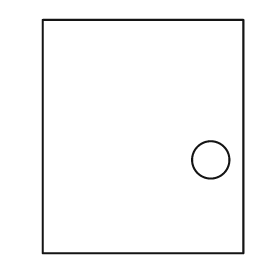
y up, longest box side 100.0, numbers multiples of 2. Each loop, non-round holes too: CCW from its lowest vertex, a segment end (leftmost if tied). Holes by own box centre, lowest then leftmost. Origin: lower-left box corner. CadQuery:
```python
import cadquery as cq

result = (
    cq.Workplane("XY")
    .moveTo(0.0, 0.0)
    .lineTo(86.0, 0.0)
    .lineTo(86.0, 100.0)
    .lineTo(0.0, 100.0)
    .close()
    .moveTo(72.0, 40.0)
    .circle(8.0)
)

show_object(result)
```